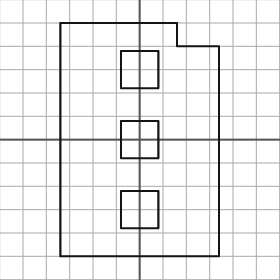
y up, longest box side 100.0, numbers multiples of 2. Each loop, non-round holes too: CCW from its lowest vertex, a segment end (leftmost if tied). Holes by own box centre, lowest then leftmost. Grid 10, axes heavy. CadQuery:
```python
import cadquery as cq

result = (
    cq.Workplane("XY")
    .moveTo(-34.0, -50.0)
    .lineTo(34.0, -50.0)
    .lineTo(34.0, 40.0)
    .lineTo(16.0, 40.0)
    .lineTo(16.0, 50.0)
    .lineTo(-34.0, 50.0)
    .close()
    .moveTo(-8.0, -38.0)
    .lineTo(8.0, -38.0)
    .lineTo(8.0, -22.0)
    .lineTo(-8.0, -22.0)
    .close()
    .moveTo(-8.0, -8.0)
    .lineTo(8.0, -8.0)
    .lineTo(8.0, 8.0)
    .lineTo(-8.0, 8.0)
    .close()
    .moveTo(-8.0, 22.0)
    .lineTo(8.0, 22.0)
    .lineTo(8.0, 38.0)
    .lineTo(-8.0, 38.0)
    .close()
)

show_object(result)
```